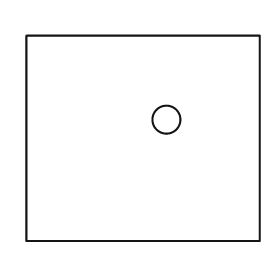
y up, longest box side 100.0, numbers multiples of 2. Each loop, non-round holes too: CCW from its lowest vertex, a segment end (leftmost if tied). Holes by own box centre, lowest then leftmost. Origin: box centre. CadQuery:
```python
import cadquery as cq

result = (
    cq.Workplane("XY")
    .moveTo(-50.0, -44.0)
    .lineTo(50.0, -44.0)
    .lineTo(50.0, 44.0)
    .lineTo(-50.0, 44.0)
    .close()
    .moveTo(10.0, 8.0)
    .circle(6.0)
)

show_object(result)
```